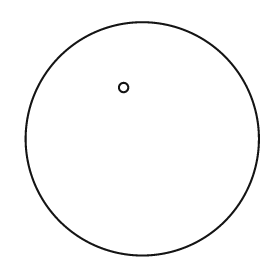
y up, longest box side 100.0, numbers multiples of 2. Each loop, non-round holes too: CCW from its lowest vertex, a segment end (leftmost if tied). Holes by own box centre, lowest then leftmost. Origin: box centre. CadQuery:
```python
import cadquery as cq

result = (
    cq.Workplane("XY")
    .moveTo(0.0, 0.0)
    .circle(50.0)
    .moveTo(-8.0, 22.0)
    .circle(2.0)
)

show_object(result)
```